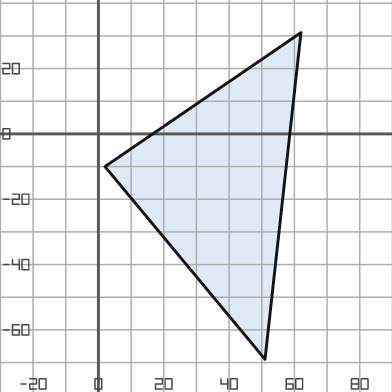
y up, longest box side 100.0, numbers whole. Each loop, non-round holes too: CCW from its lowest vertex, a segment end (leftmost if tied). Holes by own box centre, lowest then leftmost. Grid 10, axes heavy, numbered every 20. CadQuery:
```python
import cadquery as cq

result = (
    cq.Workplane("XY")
    .moveTo(51.0, -69.0)
    .lineTo(62.0, 31.0)
    .lineTo(2.0, -10.0)
    .close()
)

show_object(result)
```